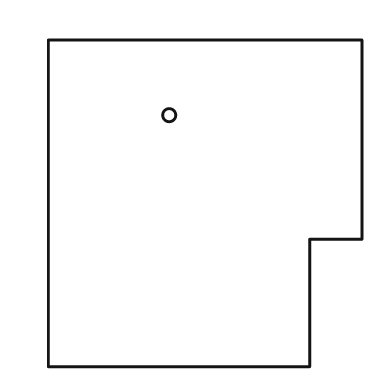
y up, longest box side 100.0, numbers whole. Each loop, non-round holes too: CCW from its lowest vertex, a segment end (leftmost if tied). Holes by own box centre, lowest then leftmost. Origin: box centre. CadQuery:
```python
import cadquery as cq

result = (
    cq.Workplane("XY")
    .moveTo(-48.0, -50.0)
    .lineTo(32.0, -50.0)
    .lineTo(32.0, -11.0)
    .lineTo(48.0, -11.0)
    .lineTo(48.0, 50.0)
    .lineTo(-48.0, 50.0)
    .close()
    .moveTo(-11.0, 27.0)
    .circle(2.0)
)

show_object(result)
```